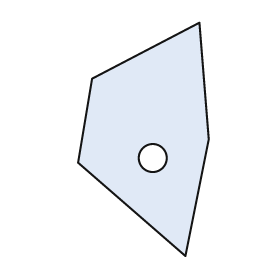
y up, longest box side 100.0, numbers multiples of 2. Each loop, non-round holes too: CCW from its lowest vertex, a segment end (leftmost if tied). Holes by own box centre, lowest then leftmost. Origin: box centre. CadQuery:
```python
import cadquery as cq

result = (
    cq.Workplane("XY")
    .moveTo(18.0, -50.0)
    .lineTo(28.0, 0.0)
    .lineTo(24.0, 50.0)
    .lineTo(-22.0, 26.0)
    .lineTo(-28.0, -10.0)
    .close()
    .moveTo(4.0, -8.0)
    .circle(6.0)
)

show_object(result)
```